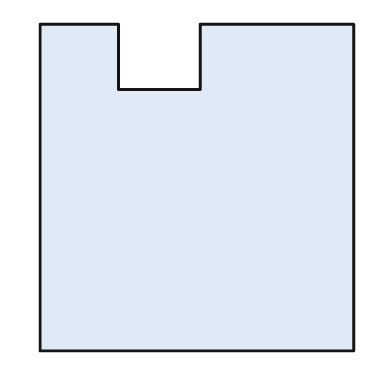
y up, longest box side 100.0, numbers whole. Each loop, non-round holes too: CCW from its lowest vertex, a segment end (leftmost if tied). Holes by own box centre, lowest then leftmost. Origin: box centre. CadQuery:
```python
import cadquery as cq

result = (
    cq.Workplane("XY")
    .moveTo(-48.0, -50.0)
    .lineTo(48.0, -50.0)
    .lineTo(48.0, 50.0)
    .lineTo(1.0, 50.0)
    .lineTo(1.0, 30.0)
    .lineTo(-24.0, 30.0)
    .lineTo(-24.0, 50.0)
    .lineTo(-48.0, 50.0)
    .close()
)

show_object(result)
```